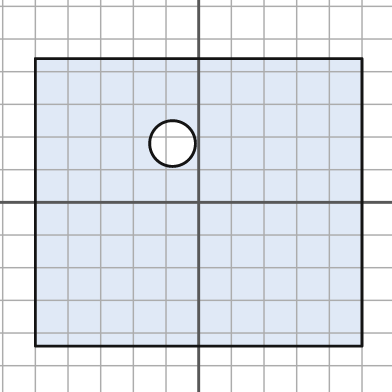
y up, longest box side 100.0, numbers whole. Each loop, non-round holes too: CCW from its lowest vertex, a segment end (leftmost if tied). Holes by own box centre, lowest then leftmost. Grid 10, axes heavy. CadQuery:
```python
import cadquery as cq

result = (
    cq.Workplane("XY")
    .moveTo(-50.0, -44.0)
    .lineTo(50.0, -44.0)
    .lineTo(50.0, 44.0)
    .lineTo(-50.0, 44.0)
    .close()
    .moveTo(-8.0, 18.0)
    .circle(7.0)
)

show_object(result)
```